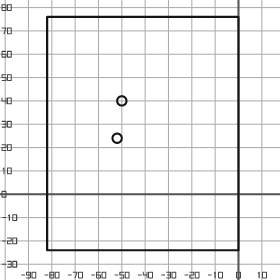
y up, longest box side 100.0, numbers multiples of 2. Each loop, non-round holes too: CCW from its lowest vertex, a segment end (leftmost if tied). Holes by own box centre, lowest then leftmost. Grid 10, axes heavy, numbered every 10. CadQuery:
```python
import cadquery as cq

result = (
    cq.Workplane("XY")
    .moveTo(-82.0, -24.0)
    .lineTo(0.0, -24.0)
    .lineTo(0.0, 76.0)
    .lineTo(-82.0, 76.0)
    .close()
    .moveTo(-52.0, 24.0)
    .circle(2.0)
    .moveTo(-50.0, 40.0)
    .circle(2.0)
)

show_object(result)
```